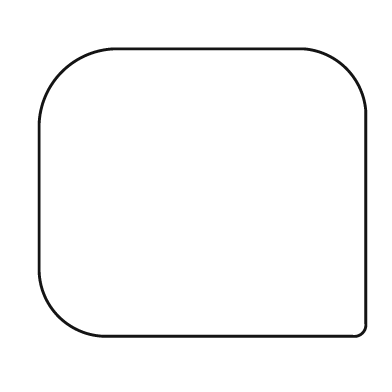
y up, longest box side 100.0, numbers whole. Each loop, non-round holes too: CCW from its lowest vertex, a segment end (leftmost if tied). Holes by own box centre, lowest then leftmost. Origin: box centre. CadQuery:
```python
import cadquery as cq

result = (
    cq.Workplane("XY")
    .moveTo(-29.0, -44.0)
    .lineTo(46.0, -44.0)
    .threePointArc((49.0, -43.0), (50.0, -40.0))
    .lineTo(50.0, 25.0)
    .threePointArc((44.0, 38.0), (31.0, 44.0))
    .lineTo(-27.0, 44.0)
    .threePointArc((-43.0, 37.0), (-50.0, 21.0))
    .lineTo(-50.0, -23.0)
    .threePointArc((-44.0, -38.0), (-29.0, -44.0))
    .close()
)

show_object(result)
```